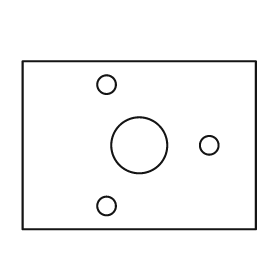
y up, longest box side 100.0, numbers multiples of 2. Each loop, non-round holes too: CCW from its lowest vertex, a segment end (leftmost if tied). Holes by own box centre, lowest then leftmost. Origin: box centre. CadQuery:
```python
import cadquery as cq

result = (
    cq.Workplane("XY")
    .moveTo(-50.0, -36.0)
    .lineTo(50.0, -36.0)
    .lineTo(50.0, 36.0)
    .lineTo(-50.0, 36.0)
    .close()
    .moveTo(-14.0, -26.0)
    .circle(4.0)
    .moveTo(0.0, 0.0)
    .circle(12.0)
    .moveTo(30.0, 0.0)
    .circle(4.0)
    .moveTo(-14.0, 26.0)
    .circle(4.0)
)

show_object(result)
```